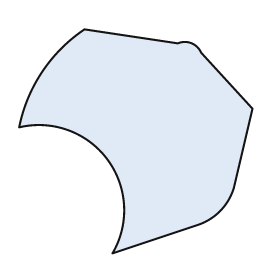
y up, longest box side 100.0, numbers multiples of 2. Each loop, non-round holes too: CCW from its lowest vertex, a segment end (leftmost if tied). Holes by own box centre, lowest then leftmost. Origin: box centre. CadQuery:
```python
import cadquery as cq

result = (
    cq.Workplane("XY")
    .moveTo(-10.0, -48.0)
    .lineTo(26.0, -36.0)
    .threePointArc((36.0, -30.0), (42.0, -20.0))
    .lineTo(50.0, 14.0)
    .lineTo(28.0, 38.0)
    .threePointArc((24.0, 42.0), (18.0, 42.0))
    .lineTo(-22.0, 48.0)
    .threePointArc((-40.0, 30.0), (-50.0, 6.0))
    .threePointArc((-12.0, -8.0), (-10.0, -48.0))
    .close()
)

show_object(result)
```